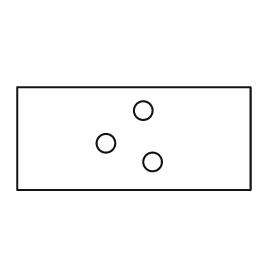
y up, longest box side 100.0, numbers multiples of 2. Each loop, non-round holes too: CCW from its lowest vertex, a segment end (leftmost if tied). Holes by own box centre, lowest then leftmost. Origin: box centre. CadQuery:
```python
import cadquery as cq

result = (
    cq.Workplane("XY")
    .moveTo(-50.0, -22.0)
    .lineTo(50.0, -22.0)
    .lineTo(50.0, 22.0)
    .lineTo(-50.0, 22.0)
    .close()
    .moveTo(8.0, -10.0)
    .circle(4.0)
    .moveTo(-12.0, -2.0)
    .circle(4.0)
    .moveTo(4.0, 12.0)
    .circle(4.0)
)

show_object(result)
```